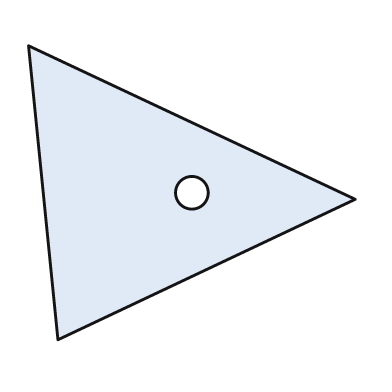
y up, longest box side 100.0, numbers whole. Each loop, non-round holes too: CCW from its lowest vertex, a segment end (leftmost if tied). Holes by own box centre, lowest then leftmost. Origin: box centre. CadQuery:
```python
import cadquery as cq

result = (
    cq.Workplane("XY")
    .moveTo(-41.0, -45.0)
    .lineTo(50.0, -2.0)
    .lineTo(-50.0, 45.0)
    .close()
    .moveTo(0.0, 0.0)
    .circle(5.0)
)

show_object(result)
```